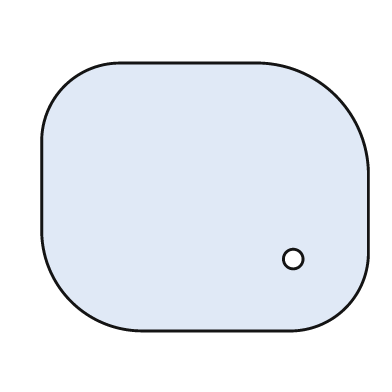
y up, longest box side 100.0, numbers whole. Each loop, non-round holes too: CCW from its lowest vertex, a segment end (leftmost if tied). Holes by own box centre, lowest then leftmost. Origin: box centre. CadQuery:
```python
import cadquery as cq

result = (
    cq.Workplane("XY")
    .moveTo(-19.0, -41.0)
    .lineTo(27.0, -41.0)
    .threePointArc((43.0, -34.0), (50.0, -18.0))
    .lineTo(50.0, 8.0)
    .threePointArc((40.0, 31.0), (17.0, 41.0))
    .lineTo(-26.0, 41.0)
    .threePointArc((-43.0, 34.0), (-50.0, 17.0))
    .lineTo(-50.0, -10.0)
    .threePointArc((-41.0, -32.0), (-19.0, -41.0))
    .close()
    .moveTo(27.0, -19.0)
    .circle(3.0)
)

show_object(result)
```